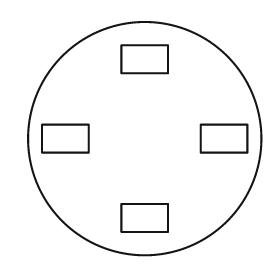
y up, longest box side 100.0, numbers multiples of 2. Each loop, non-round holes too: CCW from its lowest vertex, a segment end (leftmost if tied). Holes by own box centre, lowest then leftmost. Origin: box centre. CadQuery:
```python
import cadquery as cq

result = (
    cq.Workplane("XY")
    .moveTo(0.0, 0.0)
    .circle(50.0)
    .moveTo(-10.0, -40.0)
    .lineTo(10.0, -40.0)
    .lineTo(10.0, -28.0)
    .lineTo(-10.0, -28.0)
    .close()
    .moveTo(-44.0, -6.0)
    .lineTo(-24.0, -6.0)
    .lineTo(-24.0, 6.0)
    .lineTo(-44.0, 6.0)
    .close()
    .moveTo(24.0, -6.0)
    .lineTo(44.0, -6.0)
    .lineTo(44.0, 6.0)
    .lineTo(24.0, 6.0)
    .close()
    .moveTo(-10.0, 28.0)
    .lineTo(10.0, 28.0)
    .lineTo(10.0, 40.0)
    .lineTo(-10.0, 40.0)
    .close()
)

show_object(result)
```